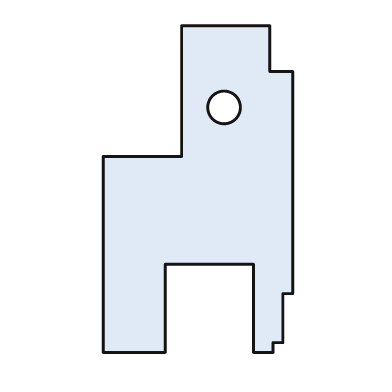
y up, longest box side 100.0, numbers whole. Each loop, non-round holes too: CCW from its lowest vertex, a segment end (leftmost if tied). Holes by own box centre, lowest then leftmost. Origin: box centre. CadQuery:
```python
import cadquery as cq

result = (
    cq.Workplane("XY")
    .moveTo(-29.0, -50.0)
    .lineTo(-10.0, -50.0)
    .lineTo(-10.0, -23.0)
    .lineTo(17.0, -23.0)
    .lineTo(17.0, -50.0)
    .lineTo(23.0, -50.0)
    .lineTo(23.0, -47.0)
    .lineTo(26.0, -47.0)
    .lineTo(26.0, -32.0)
    .lineTo(29.0, -32.0)
    .lineTo(29.0, 36.0)
    .lineTo(22.0, 36.0)
    .lineTo(22.0, 50.0)
    .lineTo(-5.0, 50.0)
    .lineTo(-5.0, 10.0)
    .lineTo(-29.0, 10.0)
    .close()
    .moveTo(8.0, 25.0)
    .circle(5.0)
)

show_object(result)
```